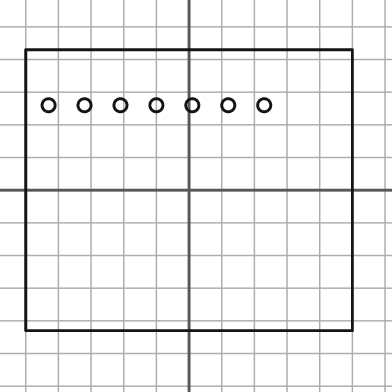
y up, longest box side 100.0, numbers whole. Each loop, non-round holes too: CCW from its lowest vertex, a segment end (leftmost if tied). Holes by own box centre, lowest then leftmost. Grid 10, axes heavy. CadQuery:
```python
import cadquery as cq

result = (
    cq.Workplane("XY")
    .moveTo(-50.0, -43.0)
    .lineTo(50.0, -43.0)
    .lineTo(50.0, 43.0)
    .lineTo(-50.0, 43.0)
    .close()
    .moveTo(-43.0, 26.0)
    .circle(2.0)
    .moveTo(-32.0, 26.0)
    .circle(2.0)
    .moveTo(-21.0, 26.0)
    .circle(2.0)
    .moveTo(-10.0, 26.0)
    .circle(2.0)
    .moveTo(1.0, 26.0)
    .circle(2.0)
    .moveTo(12.0, 26.0)
    .circle(2.0)
    .moveTo(23.0, 26.0)
    .circle(2.0)
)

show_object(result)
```